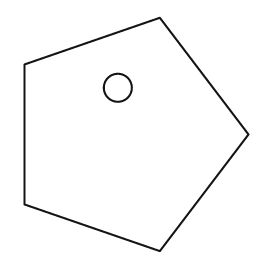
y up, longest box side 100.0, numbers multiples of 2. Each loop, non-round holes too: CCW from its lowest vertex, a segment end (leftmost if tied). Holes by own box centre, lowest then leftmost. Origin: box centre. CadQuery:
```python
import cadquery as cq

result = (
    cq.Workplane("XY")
    .moveTo(10.0, -50.0)
    .lineTo(48.0, 0.0)
    .lineTo(10.0, 50.0)
    .lineTo(-48.0, 30.0)
    .lineTo(-48.0, -30.0)
    .close()
    .moveTo(-8.0, 20.0)
    .circle(6.0)
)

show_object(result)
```